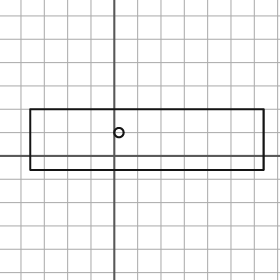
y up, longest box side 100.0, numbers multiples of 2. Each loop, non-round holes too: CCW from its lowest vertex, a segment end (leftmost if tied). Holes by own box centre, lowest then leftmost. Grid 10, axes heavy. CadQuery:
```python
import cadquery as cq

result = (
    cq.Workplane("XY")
    .moveTo(-36.0, -6.0)
    .lineTo(64.0, -6.0)
    .lineTo(64.0, 20.0)
    .lineTo(-36.0, 20.0)
    .close()
    .moveTo(2.0, 10.0)
    .circle(2.0)
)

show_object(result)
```